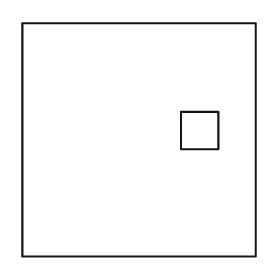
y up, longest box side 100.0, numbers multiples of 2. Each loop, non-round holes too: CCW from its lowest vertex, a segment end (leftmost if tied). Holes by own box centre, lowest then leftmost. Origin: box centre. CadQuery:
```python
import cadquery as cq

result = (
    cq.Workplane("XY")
    .moveTo(-50.0, -50.0)
    .lineTo(50.0, -50.0)
    .lineTo(50.0, 50.0)
    .lineTo(-50.0, 50.0)
    .close()
    .moveTo(18.0, -4.0)
    .lineTo(34.0, -4.0)
    .lineTo(34.0, 12.0)
    .lineTo(18.0, 12.0)
    .close()
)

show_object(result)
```